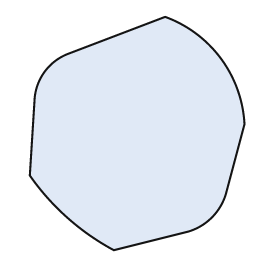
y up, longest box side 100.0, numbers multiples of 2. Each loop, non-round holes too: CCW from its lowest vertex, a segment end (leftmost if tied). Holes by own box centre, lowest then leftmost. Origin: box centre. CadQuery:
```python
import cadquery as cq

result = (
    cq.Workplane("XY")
    .moveTo(-10.0, -50.0)
    .lineTo(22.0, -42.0)
    .threePointArc((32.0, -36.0), (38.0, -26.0))
    .lineTo(46.0, 4.0)
    .threePointArc((36.0, 32.0), (12.0, 50.0))
    .lineTo(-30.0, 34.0)
    .threePointArc((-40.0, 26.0), (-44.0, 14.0))
    .lineTo(-46.0, -18.0)
    .threePointArc((-30.0, -36.0), (-10.0, -50.0))
    .close()
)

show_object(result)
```